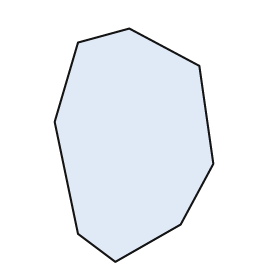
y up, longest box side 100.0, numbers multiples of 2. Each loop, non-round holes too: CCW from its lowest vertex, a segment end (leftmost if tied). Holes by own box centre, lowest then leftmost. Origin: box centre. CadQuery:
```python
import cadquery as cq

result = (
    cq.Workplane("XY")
    .moveTo(-8.0, -50.0)
    .lineTo(20.0, -34.0)
    .lineTo(34.0, -8.0)
    .lineTo(28.0, 34.0)
    .lineTo(-2.0, 50.0)
    .lineTo(-24.0, 44.0)
    .lineTo(-34.0, 10.0)
    .lineTo(-24.0, -38.0)
    .close()
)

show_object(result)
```